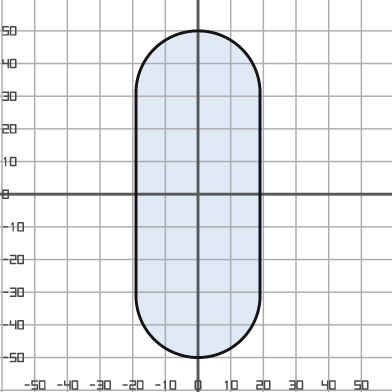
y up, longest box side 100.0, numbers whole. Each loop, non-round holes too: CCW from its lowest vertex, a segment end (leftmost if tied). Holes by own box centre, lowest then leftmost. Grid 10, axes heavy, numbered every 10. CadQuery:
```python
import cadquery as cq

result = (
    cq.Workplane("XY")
    .moveTo(-19.0, -31.0)
    .threePointArc((0.0, -50.0), (19.0, -31.0))
    .lineTo(19.0, 31.0)
    .threePointArc((0.0, 50.0), (-19.0, 31.0))
    .close()
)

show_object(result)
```